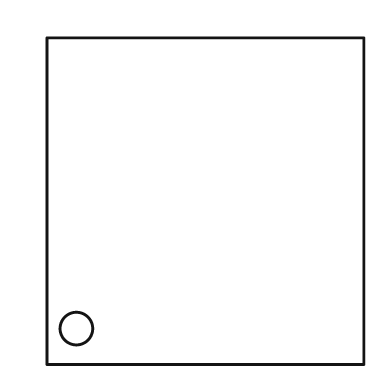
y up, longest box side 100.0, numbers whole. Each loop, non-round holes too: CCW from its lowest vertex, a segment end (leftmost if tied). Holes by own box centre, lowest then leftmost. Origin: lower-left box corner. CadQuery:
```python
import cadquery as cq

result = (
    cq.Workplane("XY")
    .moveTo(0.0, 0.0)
    .lineTo(97.0, 0.0)
    .lineTo(97.0, 100.0)
    .lineTo(0.0, 100.0)
    .close()
    .moveTo(9.0, 11.0)
    .circle(5.0)
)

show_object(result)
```